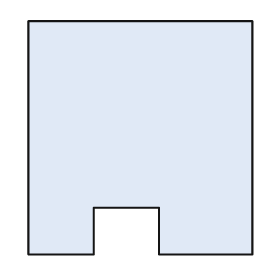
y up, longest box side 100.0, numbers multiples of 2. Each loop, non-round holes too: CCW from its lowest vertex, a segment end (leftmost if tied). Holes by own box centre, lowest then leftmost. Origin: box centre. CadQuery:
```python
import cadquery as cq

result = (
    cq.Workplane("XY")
    .moveTo(-48.0, -50.0)
    .lineTo(-20.0, -50.0)
    .lineTo(-20.0, -30.0)
    .lineTo(8.0, -30.0)
    .lineTo(8.0, -50.0)
    .lineTo(48.0, -50.0)
    .lineTo(48.0, 50.0)
    .lineTo(-48.0, 50.0)
    .close()
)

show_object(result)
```